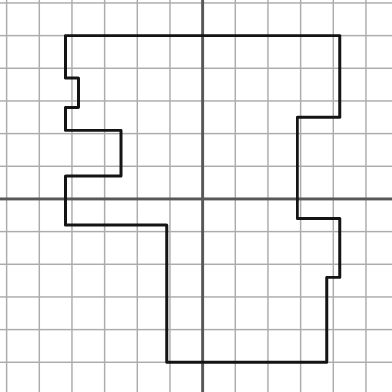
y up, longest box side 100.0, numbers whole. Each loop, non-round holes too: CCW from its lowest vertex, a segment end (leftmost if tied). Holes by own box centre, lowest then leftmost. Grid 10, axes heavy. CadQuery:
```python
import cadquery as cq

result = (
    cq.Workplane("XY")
    .moveTo(-11.0, -50.0)
    .lineTo(38.0, -50.0)
    .lineTo(38.0, -24.0)
    .lineTo(42.0, -24.0)
    .lineTo(42.0, -6.0)
    .lineTo(29.0, -6.0)
    .lineTo(29.0, 25.0)
    .lineTo(42.0, 25.0)
    .lineTo(42.0, 50.0)
    .lineTo(-42.0, 50.0)
    .lineTo(-42.0, 37.0)
    .lineTo(-38.0, 37.0)
    .lineTo(-38.0, 28.0)
    .lineTo(-42.0, 28.0)
    .lineTo(-42.0, 21.0)
    .lineTo(-25.0, 21.0)
    .lineTo(-25.0, 7.0)
    .lineTo(-42.0, 7.0)
    .lineTo(-42.0, -8.0)
    .lineTo(-11.0, -8.0)
    .close()
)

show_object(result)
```